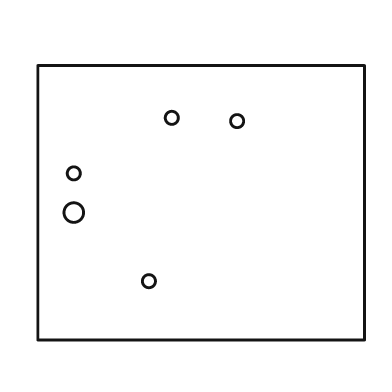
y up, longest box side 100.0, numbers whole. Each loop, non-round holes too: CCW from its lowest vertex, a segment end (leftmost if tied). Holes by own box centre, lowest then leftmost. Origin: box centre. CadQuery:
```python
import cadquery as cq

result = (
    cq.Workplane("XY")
    .moveTo(-50.0, -42.0)
    .lineTo(50.0, -42.0)
    .lineTo(50.0, 42.0)
    .lineTo(-50.0, 42.0)
    .close()
    .moveTo(-16.0, -24.0)
    .circle(2.0)
    .moveTo(-39.0, -3.0)
    .circle(3.0)
    .moveTo(-39.0, 9.0)
    .circle(2.0)
    .moveTo(11.0, 25.0)
    .circle(2.0)
    .moveTo(-9.0, 26.0)
    .circle(2.0)
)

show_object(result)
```